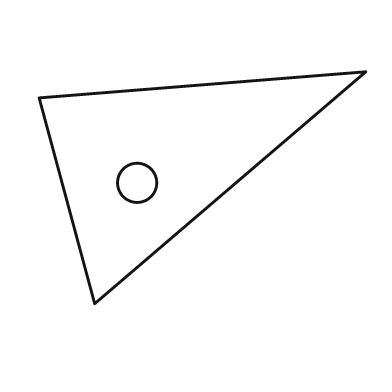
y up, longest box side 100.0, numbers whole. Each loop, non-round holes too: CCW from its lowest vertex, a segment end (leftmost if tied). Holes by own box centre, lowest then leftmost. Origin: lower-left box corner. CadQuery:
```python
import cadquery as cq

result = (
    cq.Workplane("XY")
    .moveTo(17.0, 0.0)
    .lineTo(100.0, 71.0)
    .lineTo(0.0, 63.0)
    .close()
    .moveTo(30.0, 37.0)
    .circle(6.0)
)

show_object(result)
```